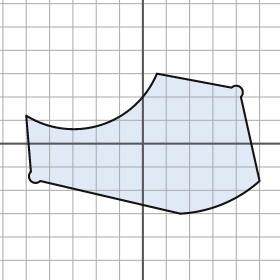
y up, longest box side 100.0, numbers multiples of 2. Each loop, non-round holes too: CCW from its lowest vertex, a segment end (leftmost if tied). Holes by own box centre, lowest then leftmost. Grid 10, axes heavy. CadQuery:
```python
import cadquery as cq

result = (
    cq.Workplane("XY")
    .moveTo(16.0, -30.0)
    .threePointArc((34.0, -26.0), (50.0, -16.0))
    .lineTo(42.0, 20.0)
    .threePointArc((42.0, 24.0), (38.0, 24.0))
    .lineTo(6.0, 30.0)
    .threePointArc((-18.0, 8.0), (-50.0, 12.0))
    .lineTo(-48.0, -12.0)
    .threePointArc((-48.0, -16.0), (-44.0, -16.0))
    .close()
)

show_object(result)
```